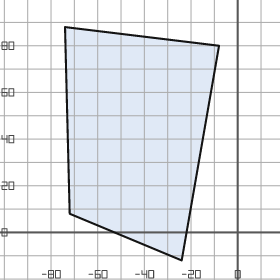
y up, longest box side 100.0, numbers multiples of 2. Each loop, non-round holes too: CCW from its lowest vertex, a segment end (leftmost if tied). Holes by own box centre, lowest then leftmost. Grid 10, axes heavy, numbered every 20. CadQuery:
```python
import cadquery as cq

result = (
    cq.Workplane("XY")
    .moveTo(-24.0, -12.0)
    .lineTo(-8.0, 80.0)
    .lineTo(-74.0, 88.0)
    .lineTo(-72.0, 8.0)
    .close()
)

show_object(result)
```